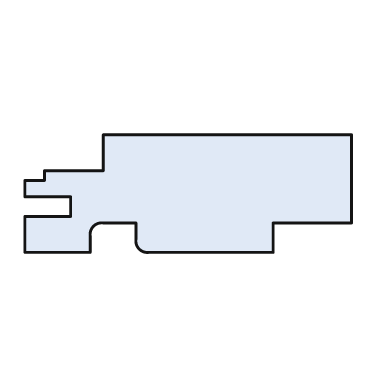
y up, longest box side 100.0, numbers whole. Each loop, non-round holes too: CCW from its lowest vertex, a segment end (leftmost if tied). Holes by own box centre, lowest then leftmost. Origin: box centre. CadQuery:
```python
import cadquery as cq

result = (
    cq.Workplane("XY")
    .moveTo(-50.0, -18.0)
    .lineTo(-30.0, -18.0)
    .lineTo(-30.0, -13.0)
    .threePointArc((-29.0, -10.0), (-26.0, -9.0))
    .lineTo(-16.0, -9.0)
    .lineTo(-16.0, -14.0)
    .threePointArc((-15.0, -17.0), (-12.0, -18.0))
    .lineTo(26.0, -18.0)
    .lineTo(26.0, -9.0)
    .lineTo(50.0, -9.0)
    .lineTo(50.0, 18.0)
    .lineTo(-26.0, 18.0)
    .lineTo(-26.0, 7.0)
    .lineTo(-44.0, 7.0)
    .lineTo(-44.0, 4.0)
    .lineTo(-50.0, 4.0)
    .lineTo(-50.0, -1.0)
    .lineTo(-36.0, -1.0)
    .lineTo(-36.0, -7.0)
    .lineTo(-50.0, -7.0)
    .close()
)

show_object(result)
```